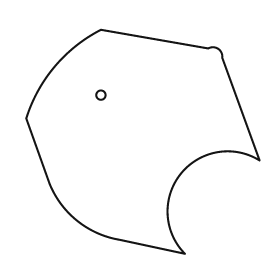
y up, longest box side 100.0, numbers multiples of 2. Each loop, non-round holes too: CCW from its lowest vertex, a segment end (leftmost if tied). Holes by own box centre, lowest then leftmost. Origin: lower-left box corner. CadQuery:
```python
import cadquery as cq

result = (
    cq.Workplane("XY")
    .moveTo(68.0, 0.0)
    .threePointArc((66.0, 34.0), (100.0, 40.0))
    .lineTo(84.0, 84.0)
    .threePointArc((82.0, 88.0), (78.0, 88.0))
    .lineTo(32.0, 96.0)
    .threePointArc((12.0, 80.0), (0.0, 58.0))
    .lineTo(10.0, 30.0)
    .threePointArc((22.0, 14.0), (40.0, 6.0))
    .close()
    .moveTo(32.0, 68.0)
    .circle(2.0)
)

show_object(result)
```